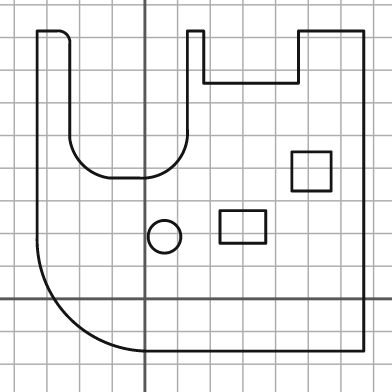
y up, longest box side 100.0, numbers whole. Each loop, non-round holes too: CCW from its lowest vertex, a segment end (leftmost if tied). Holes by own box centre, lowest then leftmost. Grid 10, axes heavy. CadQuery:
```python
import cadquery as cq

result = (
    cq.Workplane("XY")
    .moveTo(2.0, -16.0)
    .lineTo(67.0, -16.0)
    .lineTo(67.0, 82.0)
    .lineTo(47.0, 82.0)
    .lineTo(47.0, 66.0)
    .lineTo(18.0, 66.0)
    .lineTo(18.0, 82.0)
    .lineTo(13.0, 82.0)
    .lineTo(13.0, 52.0)
    .threePointArc((9.0, 41.0), (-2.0, 37.0))
    .lineTo(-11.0, 37.0)
    .threePointArc((-19.0, 41.0), (-23.0, 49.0))
    .lineTo(-23.0, 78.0)
    .threePointArc((-24.0, 81.0), (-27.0, 82.0))
    .lineTo(-33.0, 82.0)
    .lineTo(-33.0, 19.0)
    .threePointArc((-23.0, -6.0), (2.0, -16.0))
    .close()
    .moveTo(6.0, 19.0)
    .circle(5.0)
    .moveTo(23.0, 17.0)
    .lineTo(37.0, 17.0)
    .lineTo(37.0, 27.0)
    .lineTo(23.0, 27.0)
    .close()
    .moveTo(45.0, 33.0)
    .lineTo(57.0, 33.0)
    .lineTo(57.0, 45.0)
    .lineTo(45.0, 45.0)
    .close()
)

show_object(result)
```